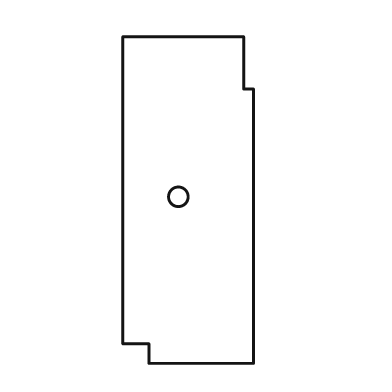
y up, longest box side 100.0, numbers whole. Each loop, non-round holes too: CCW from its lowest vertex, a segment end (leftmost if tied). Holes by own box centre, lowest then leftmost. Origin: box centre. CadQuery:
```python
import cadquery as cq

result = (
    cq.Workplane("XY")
    .moveTo(-12.0, -50.0)
    .lineTo(20.0, -50.0)
    .lineTo(20.0, 34.0)
    .lineTo(17.0, 34.0)
    .lineTo(17.0, 50.0)
    .lineTo(-20.0, 50.0)
    .lineTo(-20.0, -44.0)
    .lineTo(-12.0, -44.0)
    .close()
    .moveTo(-3.0, 1.0)
    .circle(3.0)
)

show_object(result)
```